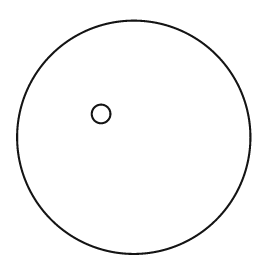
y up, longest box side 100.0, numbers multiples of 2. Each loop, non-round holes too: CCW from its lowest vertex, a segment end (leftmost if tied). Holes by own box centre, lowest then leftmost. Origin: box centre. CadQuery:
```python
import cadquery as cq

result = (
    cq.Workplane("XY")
    .moveTo(0.0, 0.0)
    .circle(50.0)
    .moveTo(-14.0, 10.0)
    .circle(4.0)
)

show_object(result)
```